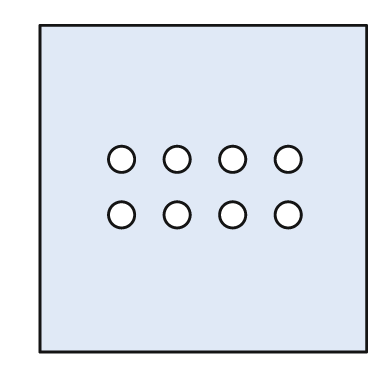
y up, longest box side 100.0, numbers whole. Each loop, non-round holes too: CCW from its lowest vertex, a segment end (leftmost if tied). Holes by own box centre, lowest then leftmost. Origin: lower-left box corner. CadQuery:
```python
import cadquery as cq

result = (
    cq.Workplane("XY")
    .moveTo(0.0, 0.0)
    .lineTo(100.0, 0.0)
    .lineTo(100.0, 100.0)
    .lineTo(0.0, 100.0)
    .close()
    .moveTo(25.0, 42.0)
    .circle(4.0)
    .moveTo(42.0, 42.0)
    .circle(4.0)
    .moveTo(59.0, 42.0)
    .circle(4.0)
    .moveTo(76.0, 42.0)
    .circle(4.0)
    .moveTo(25.0, 59.0)
    .circle(4.0)
    .moveTo(42.0, 59.0)
    .circle(4.0)
    .moveTo(59.0, 59.0)
    .circle(4.0)
    .moveTo(76.0, 59.0)
    .circle(4.0)
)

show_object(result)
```